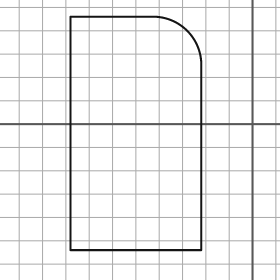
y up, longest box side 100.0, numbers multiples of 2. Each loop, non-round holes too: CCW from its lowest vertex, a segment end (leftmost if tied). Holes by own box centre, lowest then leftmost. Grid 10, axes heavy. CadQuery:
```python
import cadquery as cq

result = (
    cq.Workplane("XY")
    .moveTo(-78.0, -54.0)
    .lineTo(-22.0, -54.0)
    .lineTo(-22.0, 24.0)
    .threePointArc((-28.0, 40.0), (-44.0, 46.0))
    .lineTo(-78.0, 46.0)
    .close()
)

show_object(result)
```